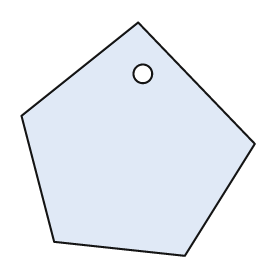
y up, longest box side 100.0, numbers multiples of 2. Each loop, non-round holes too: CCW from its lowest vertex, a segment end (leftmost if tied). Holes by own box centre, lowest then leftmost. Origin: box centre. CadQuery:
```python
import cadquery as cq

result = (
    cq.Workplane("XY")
    .moveTo(20.0, -50.0)
    .lineTo(50.0, -2.0)
    .lineTo(0.0, 50.0)
    .lineTo(-50.0, 10.0)
    .lineTo(-36.0, -44.0)
    .close()
    .moveTo(2.0, 28.0)
    .circle(4.0)
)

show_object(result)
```